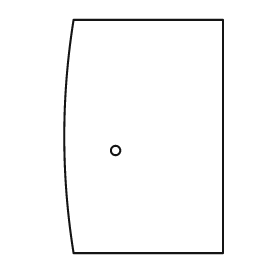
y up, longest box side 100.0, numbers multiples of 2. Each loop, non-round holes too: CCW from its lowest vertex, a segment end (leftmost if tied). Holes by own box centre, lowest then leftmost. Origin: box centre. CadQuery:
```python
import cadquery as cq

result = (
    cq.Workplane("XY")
    .moveTo(-30.0, -50.0)
    .lineTo(34.0, -50.0)
    .lineTo(34.0, 50.0)
    .lineTo(-30.0, 50.0)
    .threePointArc((-34.0, 0.0), (-30.0, -50.0))
    .close()
    .moveTo(-12.0, -6.0)
    .circle(2.0)
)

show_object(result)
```